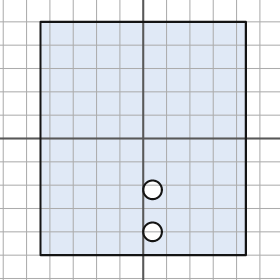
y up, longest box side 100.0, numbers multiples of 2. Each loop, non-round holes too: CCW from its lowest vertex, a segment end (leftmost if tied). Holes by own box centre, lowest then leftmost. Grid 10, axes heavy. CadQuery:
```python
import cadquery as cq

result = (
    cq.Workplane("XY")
    .moveTo(-44.0, -50.0)
    .lineTo(44.0, -50.0)
    .lineTo(44.0, 50.0)
    .lineTo(-44.0, 50.0)
    .close()
    .moveTo(4.0, -40.0)
    .circle(4.0)
    .moveTo(4.0, -22.0)
    .circle(4.0)
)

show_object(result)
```